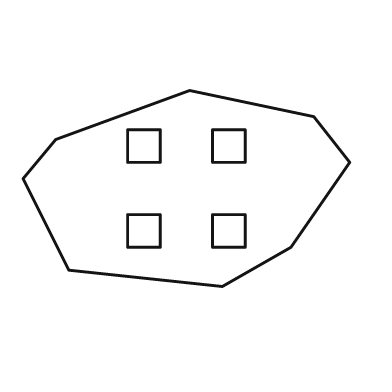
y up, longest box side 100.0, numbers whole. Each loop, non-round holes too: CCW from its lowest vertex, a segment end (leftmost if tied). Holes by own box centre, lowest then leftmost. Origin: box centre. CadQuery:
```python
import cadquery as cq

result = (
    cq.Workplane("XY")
    .moveTo(11.0, -30.0)
    .lineTo(32.0, -18.0)
    .lineTo(50.0, 8.0)
    .lineTo(39.0, 22.0)
    .lineTo(1.0, 30.0)
    .lineTo(-40.0, 15.0)
    .lineTo(-50.0, 3.0)
    .lineTo(-36.0, -25.0)
    .close()
    .moveTo(-18.0, -18.0)
    .lineTo(-8.0, -18.0)
    .lineTo(-8.0, -8.0)
    .lineTo(-18.0, -8.0)
    .close()
    .moveTo(8.0, -18.0)
    .lineTo(18.0, -18.0)
    .lineTo(18.0, -8.0)
    .lineTo(8.0, -8.0)
    .close()
    .moveTo(-18.0, 8.0)
    .lineTo(-8.0, 8.0)
    .lineTo(-8.0, 18.0)
    .lineTo(-18.0, 18.0)
    .close()
    .moveTo(8.0, 8.0)
    .lineTo(18.0, 8.0)
    .lineTo(18.0, 18.0)
    .lineTo(8.0, 18.0)
    .close()
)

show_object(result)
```